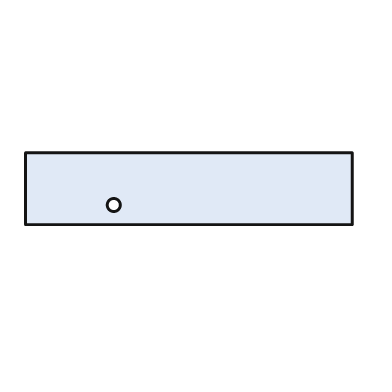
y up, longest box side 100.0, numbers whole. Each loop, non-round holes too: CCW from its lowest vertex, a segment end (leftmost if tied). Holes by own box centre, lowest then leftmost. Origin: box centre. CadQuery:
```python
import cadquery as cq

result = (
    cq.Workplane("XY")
    .moveTo(-50.0, -11.0)
    .lineTo(50.0, -11.0)
    .lineTo(50.0, 11.0)
    .lineTo(-50.0, 11.0)
    .close()
    .moveTo(-23.0, -5.0)
    .circle(2.0)
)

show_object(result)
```